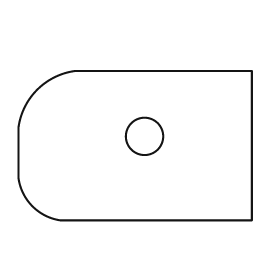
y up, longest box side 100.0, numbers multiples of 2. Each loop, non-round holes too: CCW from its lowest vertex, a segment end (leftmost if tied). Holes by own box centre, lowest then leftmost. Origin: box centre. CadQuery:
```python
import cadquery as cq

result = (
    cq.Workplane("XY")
    .moveTo(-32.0, -32.0)
    .lineTo(50.0, -32.0)
    .lineTo(50.0, 32.0)
    .lineTo(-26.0, 32.0)
    .threePointArc((-42.0, 24.0), (-50.0, 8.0))
    .lineTo(-50.0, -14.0)
    .threePointArc((-44.0, -26.0), (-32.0, -32.0))
    .close()
    .moveTo(4.0, 4.0)
    .circle(8.0)
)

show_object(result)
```